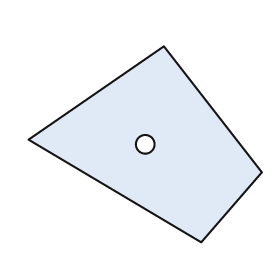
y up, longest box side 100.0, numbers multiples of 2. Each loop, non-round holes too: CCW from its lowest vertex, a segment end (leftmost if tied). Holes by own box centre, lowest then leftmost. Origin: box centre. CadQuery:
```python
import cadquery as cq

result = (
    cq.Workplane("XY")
    .moveTo(24.0, -42.0)
    .lineTo(50.0, -12.0)
    .lineTo(8.0, 42.0)
    .lineTo(-50.0, 2.0)
    .close()
    .moveTo(0.0, 0.0)
    .circle(4.0)
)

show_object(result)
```